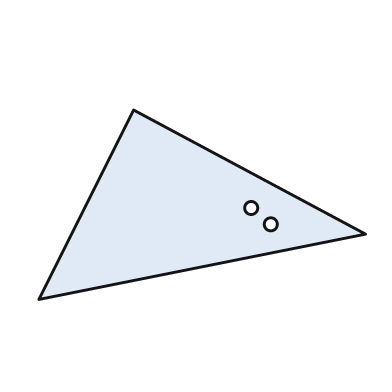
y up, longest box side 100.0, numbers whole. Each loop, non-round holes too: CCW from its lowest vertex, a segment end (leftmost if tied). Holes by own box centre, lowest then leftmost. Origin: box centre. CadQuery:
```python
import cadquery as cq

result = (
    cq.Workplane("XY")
    .moveTo(-50.0, -29.0)
    .lineTo(50.0, -9.0)
    .lineTo(-21.0, 29.0)
    .close()
    .moveTo(21.0, -6.0)
    .circle(2.0)
    .moveTo(15.0, -1.0)
    .circle(2.0)
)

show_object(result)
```